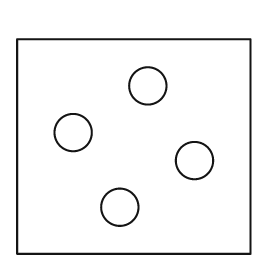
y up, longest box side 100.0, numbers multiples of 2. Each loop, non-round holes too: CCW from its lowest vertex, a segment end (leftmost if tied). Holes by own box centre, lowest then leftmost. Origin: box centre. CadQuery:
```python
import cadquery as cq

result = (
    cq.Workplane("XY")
    .moveTo(-50.0, -46.0)
    .lineTo(50.0, -46.0)
    .lineTo(50.0, 46.0)
    .lineTo(-50.0, 46.0)
    .close()
    .moveTo(-6.0, -26.0)
    .circle(8.0)
    .moveTo(26.0, -6.0)
    .circle(8.0)
    .moveTo(-26.0, 6.0)
    .circle(8.0)
    .moveTo(6.0, 26.0)
    .circle(8.0)
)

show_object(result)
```